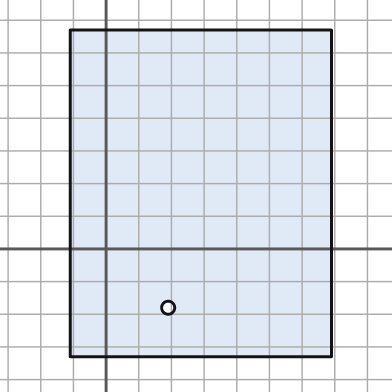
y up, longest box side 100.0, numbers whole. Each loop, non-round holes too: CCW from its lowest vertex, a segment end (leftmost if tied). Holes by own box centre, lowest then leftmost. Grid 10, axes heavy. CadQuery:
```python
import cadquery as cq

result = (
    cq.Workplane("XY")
    .moveTo(-11.0, -33.0)
    .lineTo(69.0, -33.0)
    .lineTo(69.0, 67.0)
    .lineTo(-11.0, 67.0)
    .close()
    .moveTo(19.0, -18.0)
    .circle(2.0)
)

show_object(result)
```